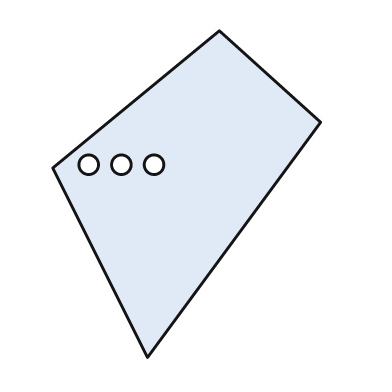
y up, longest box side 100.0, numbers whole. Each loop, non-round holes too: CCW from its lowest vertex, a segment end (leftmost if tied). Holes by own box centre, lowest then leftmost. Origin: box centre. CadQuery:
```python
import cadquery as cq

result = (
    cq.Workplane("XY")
    .moveTo(-12.0, -50.0)
    .lineTo(41.0, 22.0)
    .lineTo(10.0, 50.0)
    .lineTo(-41.0, 8.0)
    .close()
    .moveTo(-30.0, 9.0)
    .circle(3.0)
    .moveTo(-20.0, 9.0)
    .circle(3.0)
    .moveTo(-10.0, 9.0)
    .circle(3.0)
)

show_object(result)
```